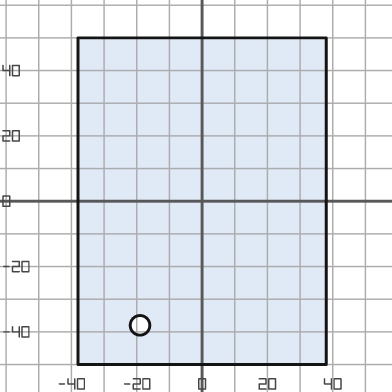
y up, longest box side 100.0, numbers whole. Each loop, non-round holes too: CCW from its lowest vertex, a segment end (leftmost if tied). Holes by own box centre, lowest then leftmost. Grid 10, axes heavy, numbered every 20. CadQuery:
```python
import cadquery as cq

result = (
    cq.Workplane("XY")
    .moveTo(-38.0, -50.0)
    .lineTo(38.0, -50.0)
    .lineTo(38.0, 50.0)
    .lineTo(-38.0, 50.0)
    .close()
    .moveTo(-19.0, -38.0)
    .circle(3.0)
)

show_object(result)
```